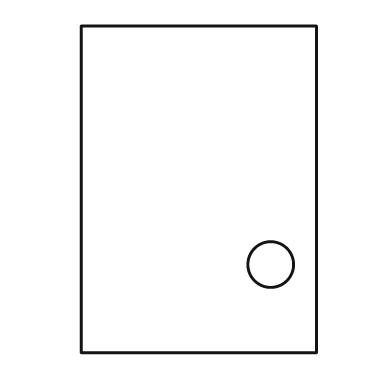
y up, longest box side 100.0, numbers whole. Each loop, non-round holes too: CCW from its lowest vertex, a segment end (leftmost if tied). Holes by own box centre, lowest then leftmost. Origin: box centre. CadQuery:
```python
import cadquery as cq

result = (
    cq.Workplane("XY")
    .moveTo(-36.0, -50.0)
    .lineTo(36.0, -50.0)
    .lineTo(36.0, 50.0)
    .lineTo(-36.0, 50.0)
    .close()
    .moveTo(22.0, -23.0)
    .circle(7.0)
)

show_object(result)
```